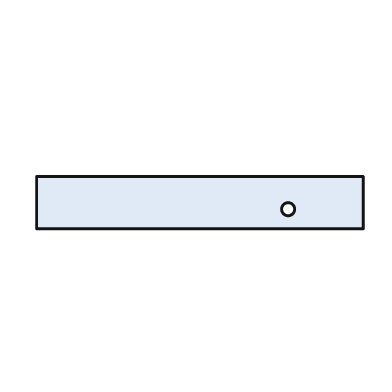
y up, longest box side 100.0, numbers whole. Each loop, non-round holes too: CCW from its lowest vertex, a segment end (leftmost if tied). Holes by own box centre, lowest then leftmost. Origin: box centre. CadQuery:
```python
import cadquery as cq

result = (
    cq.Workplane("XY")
    .moveTo(-50.0, -8.0)
    .lineTo(50.0, -8.0)
    .lineTo(50.0, 8.0)
    .lineTo(-50.0, 8.0)
    .close()
    .moveTo(27.0, -2.0)
    .circle(2.0)
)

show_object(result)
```